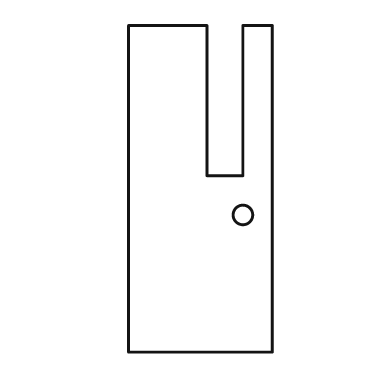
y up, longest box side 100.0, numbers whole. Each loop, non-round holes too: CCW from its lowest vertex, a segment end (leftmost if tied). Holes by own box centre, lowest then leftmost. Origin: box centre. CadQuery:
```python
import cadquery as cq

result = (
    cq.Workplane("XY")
    .moveTo(-22.0, -50.0)
    .lineTo(22.0, -50.0)
    .lineTo(22.0, 50.0)
    .lineTo(13.0, 50.0)
    .lineTo(13.0, 4.0)
    .lineTo(2.0, 4.0)
    .lineTo(2.0, 50.0)
    .lineTo(-22.0, 50.0)
    .close()
    .moveTo(13.0, -8.0)
    .circle(3.0)
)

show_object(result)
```